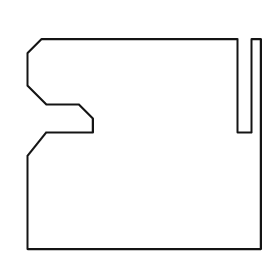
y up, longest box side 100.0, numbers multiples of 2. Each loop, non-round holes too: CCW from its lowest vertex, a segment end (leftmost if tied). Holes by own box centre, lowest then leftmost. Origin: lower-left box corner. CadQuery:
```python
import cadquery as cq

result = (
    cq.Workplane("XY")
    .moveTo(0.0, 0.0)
    .lineTo(100.0, 0.0)
    .lineTo(100.0, 90.0)
    .lineTo(96.0, 90.0)
    .lineTo(96.0, 50.0)
    .lineTo(90.0, 50.0)
    .lineTo(90.0, 90.0)
    .lineTo(6.0, 90.0)
    .lineTo(0.0, 84.0)
    .lineTo(0.0, 70.0)
    .lineTo(8.0, 62.0)
    .lineTo(22.0, 62.0)
    .lineTo(28.0, 56.0)
    .lineTo(28.0, 50.0)
    .lineTo(8.0, 50.0)
    .lineTo(0.0, 40.0)
    .close()
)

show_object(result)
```